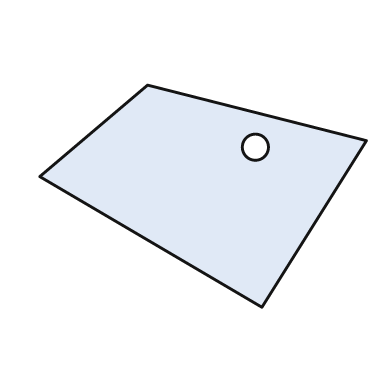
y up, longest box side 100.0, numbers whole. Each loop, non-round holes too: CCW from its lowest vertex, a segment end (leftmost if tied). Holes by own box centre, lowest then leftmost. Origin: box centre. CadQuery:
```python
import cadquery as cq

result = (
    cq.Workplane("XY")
    .moveTo(18.0, -34.0)
    .lineTo(50.0, 17.0)
    .lineTo(-17.0, 34.0)
    .lineTo(-50.0, 6.0)
    .close()
    .moveTo(16.0, 15.0)
    .circle(4.0)
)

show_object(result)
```